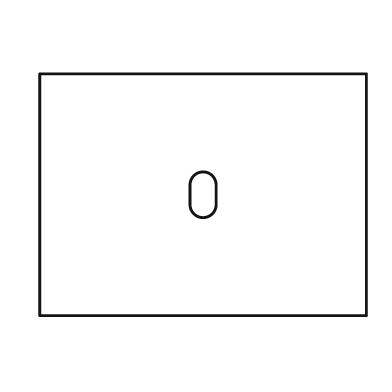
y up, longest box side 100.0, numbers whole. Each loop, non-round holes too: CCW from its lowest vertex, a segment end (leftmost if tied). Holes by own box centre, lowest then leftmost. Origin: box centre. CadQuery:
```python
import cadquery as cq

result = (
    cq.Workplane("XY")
    .moveTo(-50.0, -37.0)
    .lineTo(50.0, -37.0)
    .lineTo(50.0, 37.0)
    .lineTo(-50.0, 37.0)
    .close()
    .moveTo(-4.0, -3.0)
    .threePointArc((0.0, -7.0), (4.0, -3.0))
    .lineTo(4.0, 3.0)
    .threePointArc((0.0, 7.0), (-4.0, 3.0))
    .close()
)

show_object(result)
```